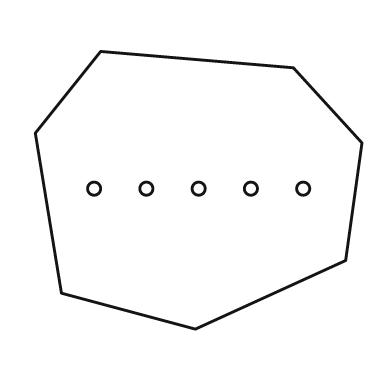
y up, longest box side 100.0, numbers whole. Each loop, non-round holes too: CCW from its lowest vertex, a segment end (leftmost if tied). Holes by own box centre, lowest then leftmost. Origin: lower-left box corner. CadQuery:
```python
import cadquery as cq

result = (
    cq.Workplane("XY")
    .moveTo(49.0, 0.0)
    .lineTo(95.0, 21.0)
    .lineTo(100.0, 57.0)
    .lineTo(79.0, 80.0)
    .lineTo(20.0, 85.0)
    .lineTo(0.0, 60.0)
    .lineTo(8.0, 11.0)
    .close()
    .moveTo(18.0, 43.0)
    .circle(2.0)
    .moveTo(34.0, 43.0)
    .circle(2.0)
    .moveTo(50.0, 43.0)
    .circle(2.0)
    .moveTo(66.0, 43.0)
    .circle(2.0)
    .moveTo(82.0, 43.0)
    .circle(2.0)
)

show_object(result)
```